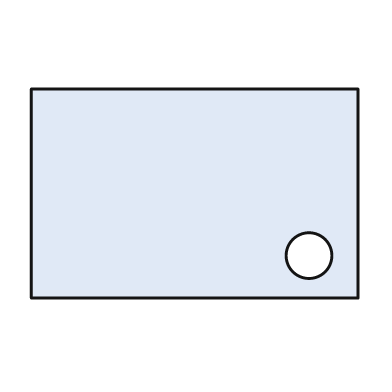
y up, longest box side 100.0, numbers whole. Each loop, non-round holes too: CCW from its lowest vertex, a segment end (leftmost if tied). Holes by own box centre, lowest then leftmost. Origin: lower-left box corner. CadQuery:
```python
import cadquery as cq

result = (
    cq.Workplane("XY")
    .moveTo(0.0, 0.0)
    .lineTo(100.0, 0.0)
    .lineTo(100.0, 64.0)
    .lineTo(0.0, 64.0)
    .close()
    .moveTo(85.0, 13.0)
    .circle(7.0)
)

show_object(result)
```